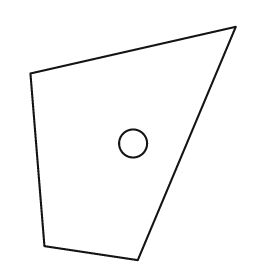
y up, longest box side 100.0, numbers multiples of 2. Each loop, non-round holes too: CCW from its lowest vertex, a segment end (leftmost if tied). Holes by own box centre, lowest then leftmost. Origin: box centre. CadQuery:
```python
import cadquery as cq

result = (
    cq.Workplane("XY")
    .moveTo(2.0, -50.0)
    .lineTo(44.0, 50.0)
    .lineTo(-44.0, 30.0)
    .lineTo(-38.0, -44.0)
    .close()
    .moveTo(0.0, 0.0)
    .circle(6.0)
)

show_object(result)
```